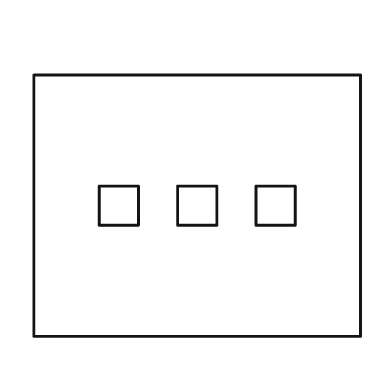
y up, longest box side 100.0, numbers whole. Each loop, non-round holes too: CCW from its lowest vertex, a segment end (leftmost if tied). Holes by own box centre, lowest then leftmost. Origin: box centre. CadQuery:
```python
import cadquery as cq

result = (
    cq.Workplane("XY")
    .moveTo(-50.0, -40.0)
    .lineTo(50.0, -40.0)
    .lineTo(50.0, 40.0)
    .lineTo(-50.0, 40.0)
    .close()
    .moveTo(-30.0, -6.0)
    .lineTo(-18.0, -6.0)
    .lineTo(-18.0, 6.0)
    .lineTo(-30.0, 6.0)
    .close()
    .moveTo(-6.0, -6.0)
    .lineTo(6.0, -6.0)
    .lineTo(6.0, 6.0)
    .lineTo(-6.0, 6.0)
    .close()
    .moveTo(18.0, -6.0)
    .lineTo(30.0, -6.0)
    .lineTo(30.0, 6.0)
    .lineTo(18.0, 6.0)
    .close()
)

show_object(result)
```